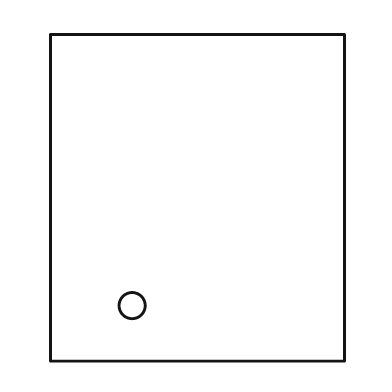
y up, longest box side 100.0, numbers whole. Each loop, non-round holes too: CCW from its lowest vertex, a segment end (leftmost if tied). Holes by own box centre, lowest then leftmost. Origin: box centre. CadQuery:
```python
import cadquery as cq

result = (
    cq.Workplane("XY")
    .moveTo(-45.0, -50.0)
    .lineTo(45.0, -50.0)
    .lineTo(45.0, 50.0)
    .lineTo(-45.0, 50.0)
    .close()
    .moveTo(-20.0, -33.0)
    .circle(4.0)
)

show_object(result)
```